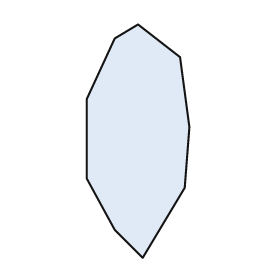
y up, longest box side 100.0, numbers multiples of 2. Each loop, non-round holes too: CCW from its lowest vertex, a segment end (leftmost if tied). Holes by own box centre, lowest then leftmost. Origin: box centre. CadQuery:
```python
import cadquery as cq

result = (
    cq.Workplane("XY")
    .moveTo(2.0, -50.0)
    .lineTo(20.0, -20.0)
    .lineTo(22.0, 6.0)
    .lineTo(18.0, 36.0)
    .lineTo(0.0, 50.0)
    .lineTo(-10.0, 44.0)
    .lineTo(-22.0, 18.0)
    .lineTo(-22.0, -16.0)
    .lineTo(-10.0, -38.0)
    .close()
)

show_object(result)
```